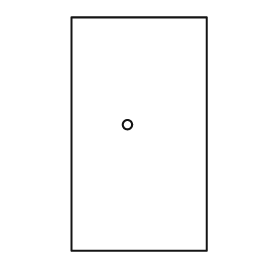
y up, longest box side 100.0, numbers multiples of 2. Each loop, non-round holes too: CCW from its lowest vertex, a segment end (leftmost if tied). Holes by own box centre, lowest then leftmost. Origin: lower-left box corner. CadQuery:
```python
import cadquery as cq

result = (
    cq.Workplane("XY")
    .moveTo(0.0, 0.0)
    .lineTo(58.0, 0.0)
    .lineTo(58.0, 100.0)
    .lineTo(0.0, 100.0)
    .close()
    .moveTo(24.0, 54.0)
    .circle(2.0)
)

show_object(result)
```